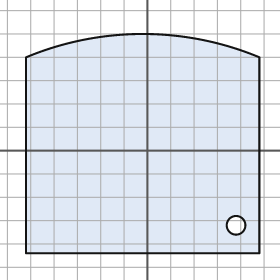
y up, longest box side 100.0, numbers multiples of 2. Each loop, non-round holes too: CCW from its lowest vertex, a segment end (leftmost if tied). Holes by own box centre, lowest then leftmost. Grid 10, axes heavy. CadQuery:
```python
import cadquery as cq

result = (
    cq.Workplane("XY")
    .moveTo(-52.0, -44.0)
    .lineTo(48.0, -44.0)
    .lineTo(48.0, 40.0)
    .threePointArc((-2.0, 50.0), (-52.0, 40.0))
    .close()
    .moveTo(38.0, -32.0)
    .circle(4.0)
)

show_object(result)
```